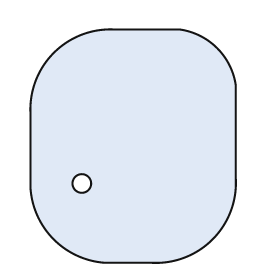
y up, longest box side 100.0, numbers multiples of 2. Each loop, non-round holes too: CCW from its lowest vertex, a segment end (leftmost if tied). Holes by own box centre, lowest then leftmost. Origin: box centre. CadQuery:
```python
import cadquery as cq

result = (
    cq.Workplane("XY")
    .moveTo(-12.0, -50.0)
    .lineTo(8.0, -50.0)
    .threePointArc((34.0, -40.0), (44.0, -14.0))
    .lineTo(44.0, 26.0)
    .threePointArc((36.0, 42.0), (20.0, 50.0))
    .lineTo(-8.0, 50.0)
    .threePointArc((-34.0, 40.0), (-44.0, 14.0))
    .lineTo(-44.0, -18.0)
    .threePointArc((-34.0, -40.0), (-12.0, -50.0))
    .close()
    .moveTo(-22.0, -16.0)
    .circle(4.0)
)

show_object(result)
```